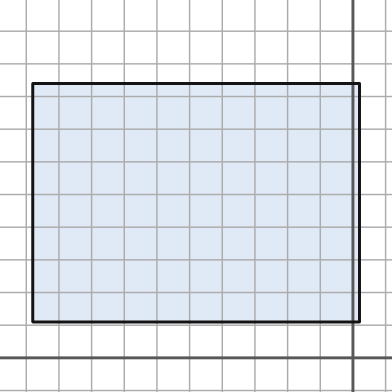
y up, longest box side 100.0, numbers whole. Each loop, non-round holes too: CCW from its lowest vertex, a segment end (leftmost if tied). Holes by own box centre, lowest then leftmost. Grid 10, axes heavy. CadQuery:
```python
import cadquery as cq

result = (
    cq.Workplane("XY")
    .moveTo(-98.0, 11.0)
    .lineTo(2.0, 11.0)
    .lineTo(2.0, 84.0)
    .lineTo(-98.0, 84.0)
    .close()
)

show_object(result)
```